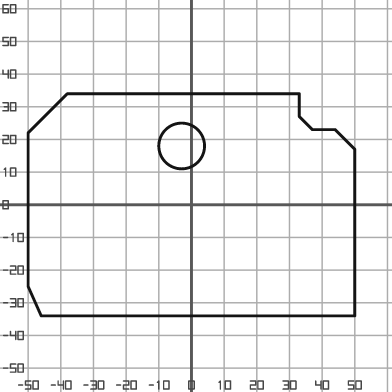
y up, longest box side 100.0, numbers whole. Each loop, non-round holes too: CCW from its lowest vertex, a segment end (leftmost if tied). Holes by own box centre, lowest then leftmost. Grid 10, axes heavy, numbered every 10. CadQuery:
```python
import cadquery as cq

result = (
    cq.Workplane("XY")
    .moveTo(-46.0, -34.0)
    .lineTo(50.0, -34.0)
    .lineTo(50.0, 17.0)
    .lineTo(44.0, 23.0)
    .lineTo(37.0, 23.0)
    .lineTo(33.0, 27.0)
    .lineTo(33.0, 34.0)
    .lineTo(-38.0, 34.0)
    .lineTo(-50.0, 22.0)
    .lineTo(-50.0, -25.0)
    .close()
    .moveTo(-3.0, 18.0)
    .circle(7.0)
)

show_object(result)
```